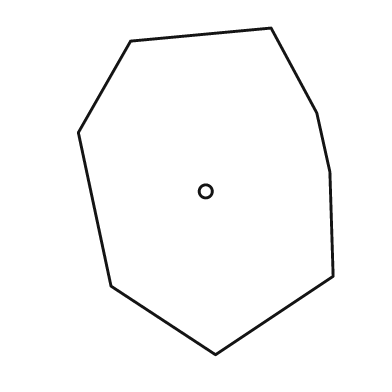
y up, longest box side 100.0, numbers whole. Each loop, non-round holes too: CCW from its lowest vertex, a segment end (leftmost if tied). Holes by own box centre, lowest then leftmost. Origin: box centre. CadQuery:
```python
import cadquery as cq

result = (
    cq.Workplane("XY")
    .moveTo(3.0, -50.0)
    .lineTo(39.0, -26.0)
    .lineTo(38.0, 6.0)
    .lineTo(34.0, 24.0)
    .lineTo(20.0, 50.0)
    .lineTo(-23.0, 46.0)
    .lineTo(-39.0, 18.0)
    .lineTo(-29.0, -29.0)
    .close()
    .moveTo(0.0, 0.0)
    .circle(2.0)
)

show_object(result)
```